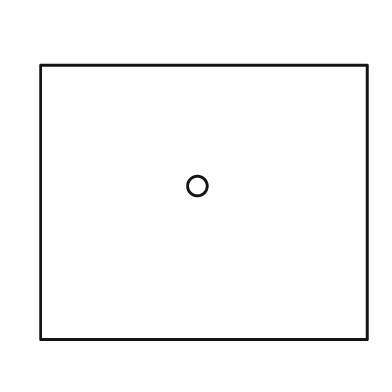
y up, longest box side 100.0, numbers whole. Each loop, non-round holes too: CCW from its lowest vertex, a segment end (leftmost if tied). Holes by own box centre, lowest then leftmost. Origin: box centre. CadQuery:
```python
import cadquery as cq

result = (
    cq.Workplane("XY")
    .moveTo(-50.0, -42.0)
    .lineTo(50.0, -42.0)
    .lineTo(50.0, 42.0)
    .lineTo(-50.0, 42.0)
    .close()
    .moveTo(-2.0, 5.0)
    .circle(3.0)
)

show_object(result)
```